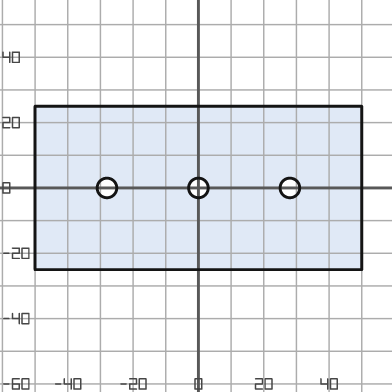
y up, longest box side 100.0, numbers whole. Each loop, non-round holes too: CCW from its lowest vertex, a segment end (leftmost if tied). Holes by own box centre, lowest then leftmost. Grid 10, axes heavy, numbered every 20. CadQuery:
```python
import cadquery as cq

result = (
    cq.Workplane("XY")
    .moveTo(-50.0, -25.0)
    .lineTo(50.0, -25.0)
    .lineTo(50.0, 25.0)
    .lineTo(-50.0, 25.0)
    .close()
    .moveTo(-28.0, 0.0)
    .circle(3.0)
    .moveTo(0.0, 0.0)
    .circle(3.0)
    .moveTo(28.0, 0.0)
    .circle(3.0)
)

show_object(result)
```